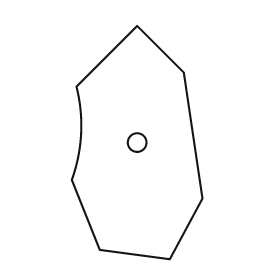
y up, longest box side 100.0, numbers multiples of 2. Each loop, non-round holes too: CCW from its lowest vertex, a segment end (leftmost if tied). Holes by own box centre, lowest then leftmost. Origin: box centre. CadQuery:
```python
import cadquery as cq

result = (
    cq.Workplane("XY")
    .moveTo(14.0, -50.0)
    .lineTo(28.0, -24.0)
    .lineTo(20.0, 30.0)
    .lineTo(0.0, 50.0)
    .lineTo(-26.0, 24.0)
    .threePointArc((-24.0, 4.0), (-28.0, -16.0))
    .lineTo(-16.0, -46.0)
    .close()
    .moveTo(0.0, 0.0)
    .circle(4.0)
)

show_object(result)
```